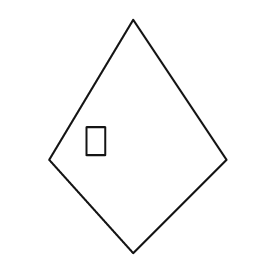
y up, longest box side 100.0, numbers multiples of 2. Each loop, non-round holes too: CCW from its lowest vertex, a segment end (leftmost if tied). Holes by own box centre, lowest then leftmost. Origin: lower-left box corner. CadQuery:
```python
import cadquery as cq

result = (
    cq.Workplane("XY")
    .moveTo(36.0, 0.0)
    .lineTo(76.0, 40.0)
    .lineTo(36.0, 100.0)
    .lineTo(0.0, 40.0)
    .close()
    .moveTo(16.0, 42.0)
    .lineTo(24.0, 42.0)
    .lineTo(24.0, 54.0)
    .lineTo(16.0, 54.0)
    .close()
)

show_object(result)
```